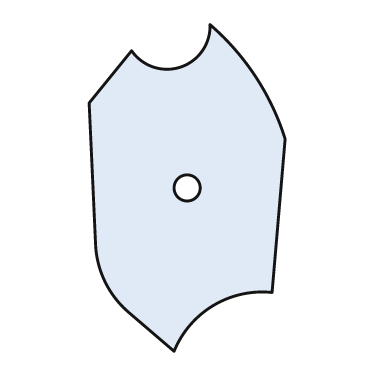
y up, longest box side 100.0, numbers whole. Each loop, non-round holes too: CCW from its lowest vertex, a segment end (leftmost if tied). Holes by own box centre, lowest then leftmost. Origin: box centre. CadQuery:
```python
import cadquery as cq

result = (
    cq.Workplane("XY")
    .moveTo(-4.0, -50.0)
    .threePointArc((8.0, -36.0), (26.0, -32.0))
    .lineTo(30.0, 15.0)
    .threePointArc((21.0, 34.0), (7.0, 50.0))
    .threePointArc((-2.0, 37.0), (-17.0, 42.0))
    .lineTo(-30.0, 26.0)
    .lineTo(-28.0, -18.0)
    .threePointArc((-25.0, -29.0), (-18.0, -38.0))
    .close()
    .moveTo(0.0, 0.0)
    .circle(4.0)
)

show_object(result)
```